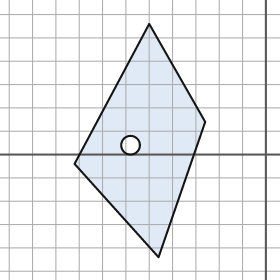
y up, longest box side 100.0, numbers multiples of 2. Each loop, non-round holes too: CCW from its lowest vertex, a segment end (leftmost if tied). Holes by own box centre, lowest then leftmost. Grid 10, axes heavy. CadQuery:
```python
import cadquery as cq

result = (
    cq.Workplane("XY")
    .moveTo(-46.0, -44.0)
    .lineTo(-26.0, 14.0)
    .lineTo(-50.0, 56.0)
    .lineTo(-82.0, -4.0)
    .close()
    .moveTo(-58.0, 4.0)
    .circle(4.0)
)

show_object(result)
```